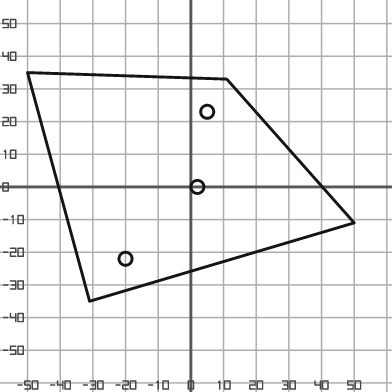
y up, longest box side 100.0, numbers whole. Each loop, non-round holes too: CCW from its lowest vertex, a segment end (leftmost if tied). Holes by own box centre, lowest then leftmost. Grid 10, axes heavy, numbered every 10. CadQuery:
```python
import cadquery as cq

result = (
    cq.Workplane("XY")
    .moveTo(-31.0, -35.0)
    .lineTo(50.0, -11.0)
    .lineTo(11.0, 33.0)
    .lineTo(-50.0, 35.0)
    .close()
    .moveTo(-20.0, -22.0)
    .circle(2.0)
    .moveTo(2.0, 0.0)
    .circle(2.0)
    .moveTo(5.0, 23.0)
    .circle(2.0)
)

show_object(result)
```